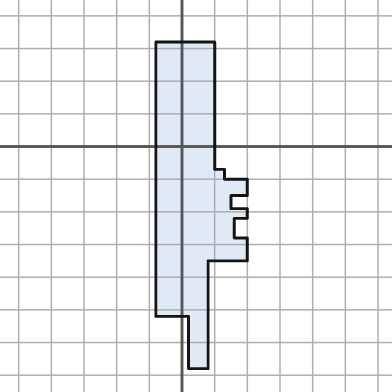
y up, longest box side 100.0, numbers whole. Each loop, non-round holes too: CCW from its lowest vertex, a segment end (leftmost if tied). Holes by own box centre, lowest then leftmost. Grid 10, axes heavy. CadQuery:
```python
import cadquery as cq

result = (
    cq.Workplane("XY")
    .moveTo(2.0, -68.0)
    .lineTo(8.0, -68.0)
    .lineTo(8.0, -35.0)
    .lineTo(20.0, -35.0)
    .lineTo(20.0, -28.0)
    .lineTo(16.0, -28.0)
    .lineTo(16.0, -22.0)
    .lineTo(20.0, -22.0)
    .lineTo(20.0, -19.0)
    .lineTo(15.0, -19.0)
    .lineTo(15.0, -15.0)
    .lineTo(20.0, -15.0)
    .lineTo(20.0, -10.0)
    .lineTo(13.0, -10.0)
    .lineTo(13.0, -7.0)
    .lineTo(10.0, -7.0)
    .lineTo(10.0, 32.0)
    .lineTo(-8.0, 32.0)
    .lineTo(-8.0, -52.0)
    .lineTo(2.0, -52.0)
    .close()
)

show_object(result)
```